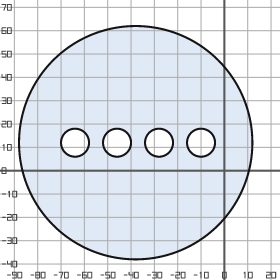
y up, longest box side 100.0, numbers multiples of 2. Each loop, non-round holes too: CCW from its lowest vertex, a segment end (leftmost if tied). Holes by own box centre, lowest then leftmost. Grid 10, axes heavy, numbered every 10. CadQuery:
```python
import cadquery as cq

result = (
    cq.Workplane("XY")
    .moveTo(-38.0, 12.0)
    .circle(50.0)
    .moveTo(-64.0, 12.0)
    .circle(6.0)
    .moveTo(-46.0, 12.0)
    .circle(6.0)
    .moveTo(-28.0, 12.0)
    .circle(6.0)
    .moveTo(-10.0, 12.0)
    .circle(6.0)
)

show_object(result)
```